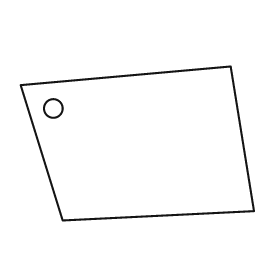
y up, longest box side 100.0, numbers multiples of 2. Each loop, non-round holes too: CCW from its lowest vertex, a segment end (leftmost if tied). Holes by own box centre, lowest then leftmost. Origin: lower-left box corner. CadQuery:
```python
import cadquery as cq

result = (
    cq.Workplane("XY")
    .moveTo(18.0, 0.0)
    .lineTo(100.0, 4.0)
    .lineTo(90.0, 66.0)
    .lineTo(0.0, 58.0)
    .close()
    .moveTo(14.0, 48.0)
    .circle(4.0)
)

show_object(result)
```